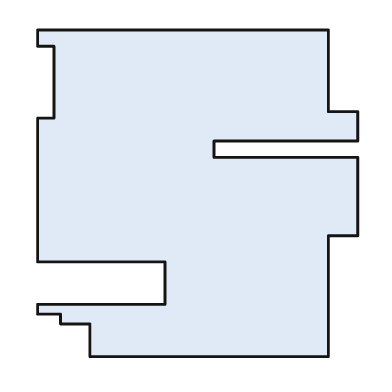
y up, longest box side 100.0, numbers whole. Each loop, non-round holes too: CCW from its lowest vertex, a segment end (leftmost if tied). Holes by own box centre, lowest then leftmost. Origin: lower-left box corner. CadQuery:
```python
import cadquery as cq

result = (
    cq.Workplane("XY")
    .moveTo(16.0, 0.0)
    .lineTo(89.0, 0.0)
    .lineTo(89.0, 37.0)
    .lineTo(98.0, 37.0)
    .lineTo(98.0, 61.0)
    .lineTo(54.0, 61.0)
    .lineTo(54.0, 66.0)
    .lineTo(98.0, 66.0)
    .lineTo(98.0, 75.0)
    .lineTo(89.0, 75.0)
    .lineTo(89.0, 100.0)
    .lineTo(0.0, 100.0)
    .lineTo(0.0, 95.0)
    .lineTo(5.0, 95.0)
    .lineTo(5.0, 73.0)
    .lineTo(0.0, 73.0)
    .lineTo(0.0, 29.0)
    .lineTo(39.0, 29.0)
    .lineTo(39.0, 16.0)
    .lineTo(0.0, 16.0)
    .lineTo(0.0, 13.0)
    .lineTo(7.0, 13.0)
    .lineTo(7.0, 10.0)
    .lineTo(16.0, 10.0)
    .close()
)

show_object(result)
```